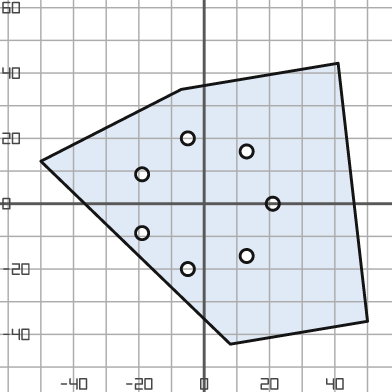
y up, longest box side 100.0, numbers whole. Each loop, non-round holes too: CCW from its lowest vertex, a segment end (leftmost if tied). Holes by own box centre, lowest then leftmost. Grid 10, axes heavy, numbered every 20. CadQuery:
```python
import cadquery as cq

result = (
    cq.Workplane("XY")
    .moveTo(8.0, -43.0)
    .lineTo(50.0, -36.0)
    .lineTo(41.0, 43.0)
    .lineTo(-7.0, 35.0)
    .lineTo(-50.0, 13.0)
    .close()
    .moveTo(-5.0, -20.0)
    .circle(2.0)
    .moveTo(13.0, -16.0)
    .circle(2.0)
    .moveTo(-19.0, -9.0)
    .circle(2.0)
    .moveTo(21.0, 0.0)
    .circle(2.0)
    .moveTo(-19.0, 9.0)
    .circle(2.0)
    .moveTo(13.0, 16.0)
    .circle(2.0)
    .moveTo(-5.0, 20.0)
    .circle(2.0)
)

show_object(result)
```